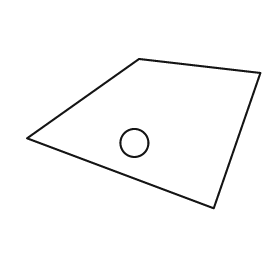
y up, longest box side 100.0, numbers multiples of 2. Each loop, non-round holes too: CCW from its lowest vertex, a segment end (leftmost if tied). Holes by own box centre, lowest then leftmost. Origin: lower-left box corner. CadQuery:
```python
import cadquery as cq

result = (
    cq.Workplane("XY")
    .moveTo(80.0, 0.0)
    .lineTo(100.0, 58.0)
    .lineTo(48.0, 64.0)
    .lineTo(0.0, 30.0)
    .close()
    .moveTo(46.0, 28.0)
    .circle(6.0)
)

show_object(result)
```